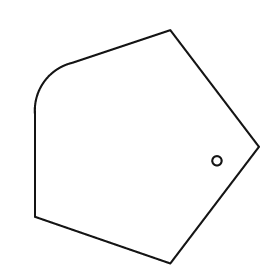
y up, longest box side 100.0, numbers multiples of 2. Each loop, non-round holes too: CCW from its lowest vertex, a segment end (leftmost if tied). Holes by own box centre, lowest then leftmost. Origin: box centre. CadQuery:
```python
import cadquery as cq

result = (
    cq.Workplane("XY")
    .moveTo(10.0, -50.0)
    .lineTo(48.0, 0.0)
    .lineTo(10.0, 50.0)
    .lineTo(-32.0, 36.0)
    .threePointArc((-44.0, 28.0), (-48.0, 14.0))
    .lineTo(-48.0, -30.0)
    .close()
    .moveTo(30.0, -6.0)
    .circle(2.0)
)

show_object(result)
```